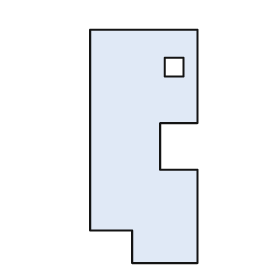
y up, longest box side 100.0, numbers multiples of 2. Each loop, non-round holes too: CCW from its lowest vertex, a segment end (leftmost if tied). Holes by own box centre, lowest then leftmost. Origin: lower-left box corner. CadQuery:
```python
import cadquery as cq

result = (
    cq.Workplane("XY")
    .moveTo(18.0, 0.0)
    .lineTo(46.0, 0.0)
    .lineTo(46.0, 40.0)
    .lineTo(30.0, 40.0)
    .lineTo(30.0, 60.0)
    .lineTo(46.0, 60.0)
    .lineTo(46.0, 100.0)
    .lineTo(0.0, 100.0)
    .lineTo(0.0, 14.0)
    .lineTo(18.0, 14.0)
    .close()
    .moveTo(32.0, 80.0)
    .lineTo(40.0, 80.0)
    .lineTo(40.0, 88.0)
    .lineTo(32.0, 88.0)
    .close()
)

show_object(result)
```